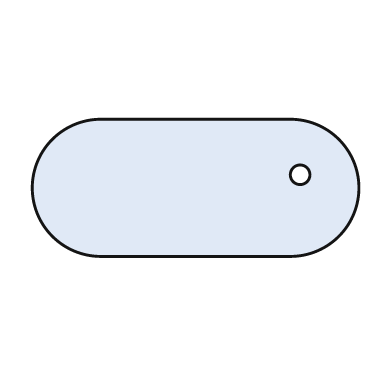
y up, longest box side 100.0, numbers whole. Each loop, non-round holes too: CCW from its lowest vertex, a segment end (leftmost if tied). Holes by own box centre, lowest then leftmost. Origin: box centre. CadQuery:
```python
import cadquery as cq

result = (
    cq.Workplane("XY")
    .moveTo(-29.0, -21.0)
    .lineTo(29.0, -21.0)
    .threePointArc((50.0, 0.0), (29.0, 21.0))
    .lineTo(-29.0, 21.0)
    .threePointArc((-50.0, 0.0), (-29.0, -21.0))
    .close()
    .moveTo(32.0, 4.0)
    .circle(3.0)
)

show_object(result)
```